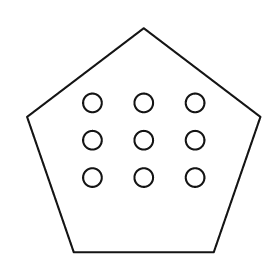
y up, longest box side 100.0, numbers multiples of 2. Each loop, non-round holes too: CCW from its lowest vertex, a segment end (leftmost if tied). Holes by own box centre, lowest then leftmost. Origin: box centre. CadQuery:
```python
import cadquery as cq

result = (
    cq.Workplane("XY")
    .moveTo(-30.0, -48.0)
    .lineTo(30.0, -48.0)
    .lineTo(50.0, 10.0)
    .lineTo(0.0, 48.0)
    .lineTo(-50.0, 10.0)
    .close()
    .moveTo(-22.0, -16.0)
    .circle(4.0)
    .moveTo(0.0, -16.0)
    .circle(4.0)
    .moveTo(22.0, -16.0)
    .circle(4.0)
    .moveTo(-22.0, 0.0)
    .circle(4.0)
    .moveTo(0.0, 0.0)
    .circle(4.0)
    .moveTo(22.0, 0.0)
    .circle(4.0)
    .moveTo(-22.0, 16.0)
    .circle(4.0)
    .moveTo(0.0, 16.0)
    .circle(4.0)
    .moveTo(22.0, 16.0)
    .circle(4.0)
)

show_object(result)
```